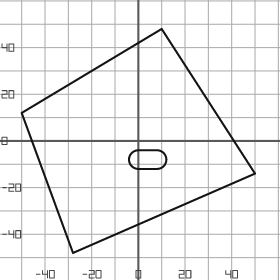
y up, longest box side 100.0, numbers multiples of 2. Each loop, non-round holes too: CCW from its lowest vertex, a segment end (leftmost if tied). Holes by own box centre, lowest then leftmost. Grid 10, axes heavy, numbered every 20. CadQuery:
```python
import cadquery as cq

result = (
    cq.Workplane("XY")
    .moveTo(-28.0, -48.0)
    .lineTo(50.0, -14.0)
    .lineTo(10.0, 48.0)
    .lineTo(-50.0, 12.0)
    .close()
    .moveTo(0.0, -12.0)
    .lineTo(8.0, -12.0)
    .threePointArc((12.0, -8.0), (8.0, -4.0))
    .lineTo(0.0, -4.0)
    .threePointArc((-4.0, -8.0), (0.0, -12.0))
    .close()
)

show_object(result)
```